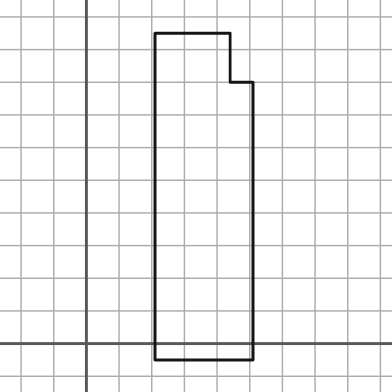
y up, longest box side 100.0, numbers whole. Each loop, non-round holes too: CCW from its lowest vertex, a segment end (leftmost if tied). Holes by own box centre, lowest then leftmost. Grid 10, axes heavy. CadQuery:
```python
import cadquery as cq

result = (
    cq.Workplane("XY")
    .moveTo(21.0, -5.0)
    .lineTo(51.0, -5.0)
    .lineTo(51.0, 80.0)
    .lineTo(44.0, 80.0)
    .lineTo(44.0, 95.0)
    .lineTo(21.0, 95.0)
    .close()
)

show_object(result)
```